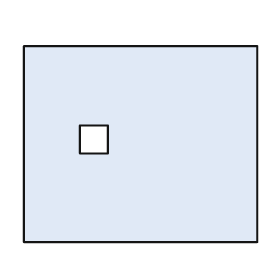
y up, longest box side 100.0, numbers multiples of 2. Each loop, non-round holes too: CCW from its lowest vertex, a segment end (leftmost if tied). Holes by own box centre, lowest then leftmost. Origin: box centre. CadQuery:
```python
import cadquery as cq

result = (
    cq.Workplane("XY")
    .moveTo(-50.0, -42.0)
    .lineTo(50.0, -42.0)
    .lineTo(50.0, 42.0)
    .lineTo(-50.0, 42.0)
    .close()
    .moveTo(-26.0, -4.0)
    .lineTo(-14.0, -4.0)
    .lineTo(-14.0, 8.0)
    .lineTo(-26.0, 8.0)
    .close()
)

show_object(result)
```